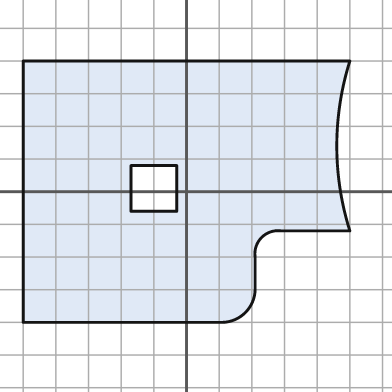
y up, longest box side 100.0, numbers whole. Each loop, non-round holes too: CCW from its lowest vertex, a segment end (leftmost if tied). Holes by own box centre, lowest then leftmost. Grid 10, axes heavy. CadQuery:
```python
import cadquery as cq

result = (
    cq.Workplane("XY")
    .moveTo(-50.0, -40.0)
    .lineTo(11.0, -40.0)
    .threePointArc((18.0, -37.0), (21.0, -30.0))
    .lineTo(21.0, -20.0)
    .threePointArc((23.0, -14.0), (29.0, -12.0))
    .lineTo(50.0, -12.0)
    .threePointArc((46.0, 14.0), (50.0, 40.0))
    .lineTo(-50.0, 40.0)
    .close()
    .moveTo(-17.0, -6.0)
    .lineTo(-3.0, -6.0)
    .lineTo(-3.0, 8.0)
    .lineTo(-17.0, 8.0)
    .close()
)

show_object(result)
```